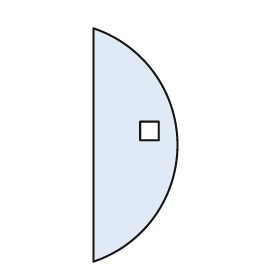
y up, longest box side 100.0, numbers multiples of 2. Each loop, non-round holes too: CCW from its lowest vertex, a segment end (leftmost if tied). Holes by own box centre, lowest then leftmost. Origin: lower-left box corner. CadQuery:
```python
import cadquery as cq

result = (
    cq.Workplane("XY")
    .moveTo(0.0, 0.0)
    .threePointArc((36.0, 50.0), (0.0, 100.0))
    .close()
    .moveTo(20.0, 52.0)
    .lineTo(28.0, 52.0)
    .lineTo(28.0, 60.0)
    .lineTo(20.0, 60.0)
    .close()
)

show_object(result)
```